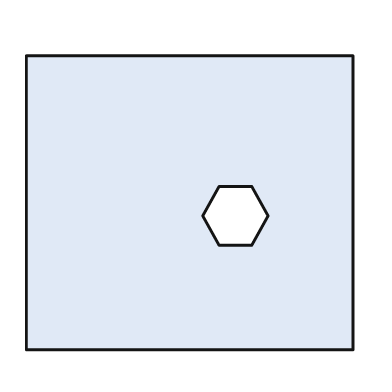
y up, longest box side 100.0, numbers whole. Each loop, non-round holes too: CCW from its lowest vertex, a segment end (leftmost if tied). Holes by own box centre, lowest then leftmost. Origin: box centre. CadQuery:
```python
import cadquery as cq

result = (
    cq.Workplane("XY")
    .moveTo(-50.0, -45.0)
    .lineTo(50.0, -45.0)
    .lineTo(50.0, 45.0)
    .lineTo(-50.0, 45.0)
    .close()
    .moveTo(9.0, -13.0)
    .lineTo(19.0, -13.0)
    .lineTo(24.0, -4.0)
    .lineTo(19.0, 5.0)
    .lineTo(9.0, 5.0)
    .lineTo(4.0, -4.0)
    .close()
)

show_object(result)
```